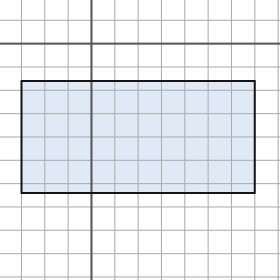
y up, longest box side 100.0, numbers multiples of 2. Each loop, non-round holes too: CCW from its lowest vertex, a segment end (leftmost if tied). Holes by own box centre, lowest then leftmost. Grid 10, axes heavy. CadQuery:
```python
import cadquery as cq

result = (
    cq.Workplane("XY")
    .moveTo(-30.0, -64.0)
    .lineTo(70.0, -64.0)
    .lineTo(70.0, -16.0)
    .lineTo(-30.0, -16.0)
    .close()
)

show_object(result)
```